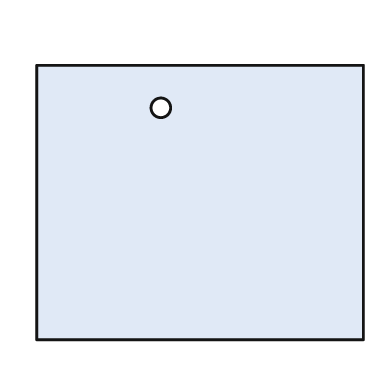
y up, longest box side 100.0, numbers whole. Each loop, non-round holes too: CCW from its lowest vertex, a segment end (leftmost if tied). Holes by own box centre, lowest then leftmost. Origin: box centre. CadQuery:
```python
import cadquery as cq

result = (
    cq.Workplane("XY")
    .moveTo(-50.0, -42.0)
    .lineTo(50.0, -42.0)
    .lineTo(50.0, 42.0)
    .lineTo(-50.0, 42.0)
    .close()
    .moveTo(-12.0, 29.0)
    .circle(3.0)
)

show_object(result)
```